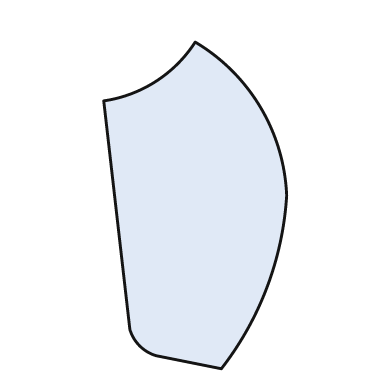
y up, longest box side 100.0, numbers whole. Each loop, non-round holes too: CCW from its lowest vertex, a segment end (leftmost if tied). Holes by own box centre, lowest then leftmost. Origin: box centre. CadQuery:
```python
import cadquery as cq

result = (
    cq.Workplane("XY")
    .moveTo(8.0, -50.0)
    .threePointArc((22.0, -25.0), (28.0, 3.0))
    .threePointArc((20.0, 30.0), (0.0, 50.0))
    .threePointArc((-12.0, 38.0), (-28.0, 32.0))
    .lineTo(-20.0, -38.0)
    .threePointArc((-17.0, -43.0), (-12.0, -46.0))
    .close()
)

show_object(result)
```